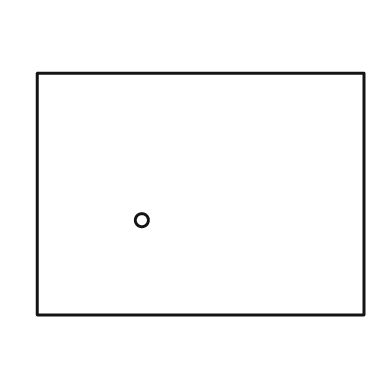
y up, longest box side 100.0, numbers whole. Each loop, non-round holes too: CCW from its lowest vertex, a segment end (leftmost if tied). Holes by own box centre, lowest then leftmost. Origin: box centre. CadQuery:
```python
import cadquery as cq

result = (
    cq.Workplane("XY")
    .moveTo(-50.0, -37.0)
    .lineTo(50.0, -37.0)
    .lineTo(50.0, 37.0)
    .lineTo(-50.0, 37.0)
    .close()
    .moveTo(-18.0, -8.0)
    .circle(2.0)
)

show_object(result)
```